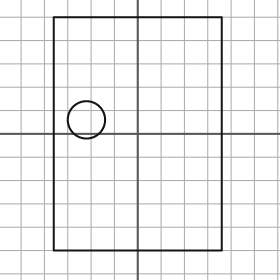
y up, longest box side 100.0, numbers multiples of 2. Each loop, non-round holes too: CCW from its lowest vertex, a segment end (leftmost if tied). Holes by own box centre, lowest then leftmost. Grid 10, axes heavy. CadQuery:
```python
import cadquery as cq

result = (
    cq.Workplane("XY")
    .moveTo(-36.0, -50.0)
    .lineTo(36.0, -50.0)
    .lineTo(36.0, 50.0)
    .lineTo(-36.0, 50.0)
    .close()
    .moveTo(-22.0, 6.0)
    .circle(8.0)
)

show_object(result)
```